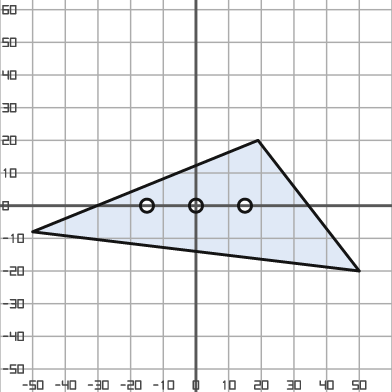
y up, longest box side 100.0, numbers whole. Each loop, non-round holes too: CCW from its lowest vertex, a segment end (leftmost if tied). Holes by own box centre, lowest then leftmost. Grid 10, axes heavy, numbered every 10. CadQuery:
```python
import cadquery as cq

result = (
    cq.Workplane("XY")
    .moveTo(50.0, -20.0)
    .lineTo(19.0, 20.0)
    .lineTo(-50.0, -8.0)
    .close()
    .moveTo(-15.0, 0.0)
    .circle(2.0)
    .moveTo(0.0, 0.0)
    .circle(2.0)
    .moveTo(15.0, 0.0)
    .circle(2.0)
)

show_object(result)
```